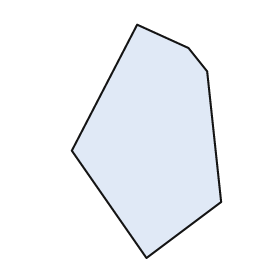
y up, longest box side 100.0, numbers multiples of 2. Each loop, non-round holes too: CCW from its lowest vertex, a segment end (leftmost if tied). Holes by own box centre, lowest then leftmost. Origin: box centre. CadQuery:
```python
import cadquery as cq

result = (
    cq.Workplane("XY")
    .moveTo(0.0, -50.0)
    .lineTo(32.0, -26.0)
    .lineTo(26.0, 30.0)
    .lineTo(18.0, 40.0)
    .lineTo(-4.0, 50.0)
    .lineTo(-32.0, -4.0)
    .close()
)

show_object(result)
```